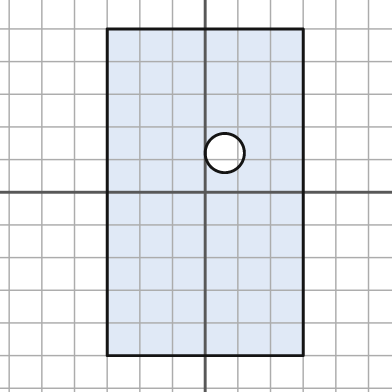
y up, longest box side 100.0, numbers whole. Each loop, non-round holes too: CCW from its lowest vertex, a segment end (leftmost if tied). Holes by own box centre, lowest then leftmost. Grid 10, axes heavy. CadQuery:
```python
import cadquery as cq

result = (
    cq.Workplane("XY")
    .moveTo(-30.0, -50.0)
    .lineTo(30.0, -50.0)
    .lineTo(30.0, 50.0)
    .lineTo(-30.0, 50.0)
    .close()
    .moveTo(6.0, 12.0)
    .circle(6.0)
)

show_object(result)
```